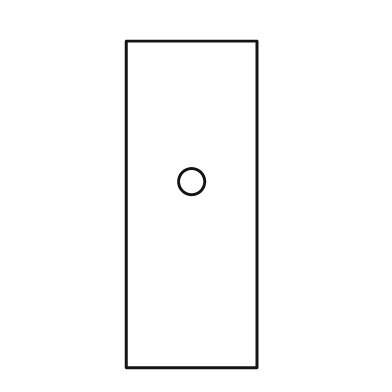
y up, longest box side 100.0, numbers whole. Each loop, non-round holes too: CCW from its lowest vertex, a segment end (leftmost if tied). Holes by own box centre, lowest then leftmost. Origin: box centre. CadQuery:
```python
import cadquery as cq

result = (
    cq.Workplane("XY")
    .moveTo(-20.0, -50.0)
    .lineTo(20.0, -50.0)
    .lineTo(20.0, 50.0)
    .lineTo(-20.0, 50.0)
    .close()
    .moveTo(0.0, 7.0)
    .circle(4.0)
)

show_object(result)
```